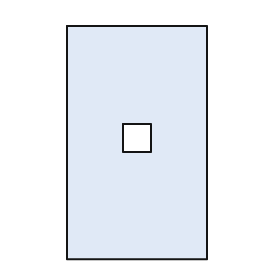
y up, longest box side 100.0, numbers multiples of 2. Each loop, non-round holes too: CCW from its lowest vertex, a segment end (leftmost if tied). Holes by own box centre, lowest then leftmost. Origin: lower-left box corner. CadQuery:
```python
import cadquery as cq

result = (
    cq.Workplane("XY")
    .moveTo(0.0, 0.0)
    .lineTo(60.0, 0.0)
    .lineTo(60.0, 100.0)
    .lineTo(0.0, 100.0)
    .close()
    .moveTo(24.0, 46.0)
    .lineTo(36.0, 46.0)
    .lineTo(36.0, 58.0)
    .lineTo(24.0, 58.0)
    .close()
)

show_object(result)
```